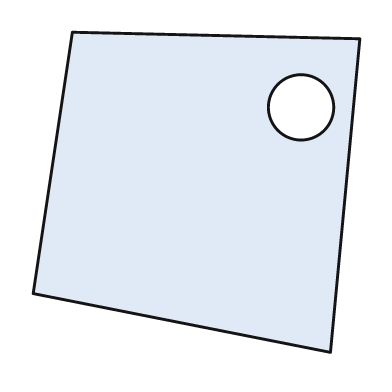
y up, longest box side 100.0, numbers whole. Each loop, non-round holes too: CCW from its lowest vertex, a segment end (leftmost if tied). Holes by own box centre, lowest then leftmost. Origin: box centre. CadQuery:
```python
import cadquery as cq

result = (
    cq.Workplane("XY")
    .moveTo(41.0, -49.0)
    .lineTo(50.0, 47.0)
    .lineTo(-38.0, 49.0)
    .lineTo(-50.0, -31.0)
    .close()
    .moveTo(32.0, 26.0)
    .circle(10.0)
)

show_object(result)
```